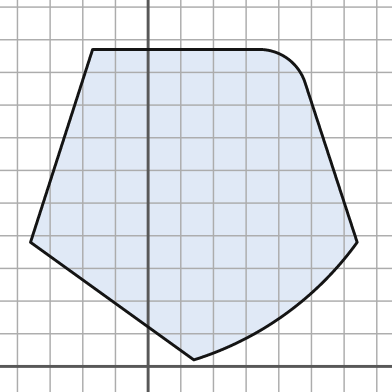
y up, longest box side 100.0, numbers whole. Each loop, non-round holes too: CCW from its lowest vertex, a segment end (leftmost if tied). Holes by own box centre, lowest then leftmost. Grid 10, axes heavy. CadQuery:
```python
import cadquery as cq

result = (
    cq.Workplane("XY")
    .moveTo(14.0, 2.0)
    .threePointArc((42.0, 16.0), (64.0, 38.0))
    .lineTo(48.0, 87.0)
    .threePointArc((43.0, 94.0), (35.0, 97.0))
    .lineTo(-17.0, 97.0)
    .lineTo(-36.0, 38.0)
    .close()
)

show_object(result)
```